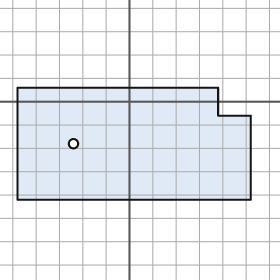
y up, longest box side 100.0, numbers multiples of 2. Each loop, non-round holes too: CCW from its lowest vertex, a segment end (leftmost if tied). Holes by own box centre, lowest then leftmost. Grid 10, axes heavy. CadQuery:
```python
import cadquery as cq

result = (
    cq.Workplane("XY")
    .moveTo(-48.0, -42.0)
    .lineTo(52.0, -42.0)
    .lineTo(52.0, -6.0)
    .lineTo(38.0, -6.0)
    .lineTo(38.0, 6.0)
    .lineTo(-48.0, 6.0)
    .close()
    .moveTo(-24.0, -18.0)
    .circle(2.0)
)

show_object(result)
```